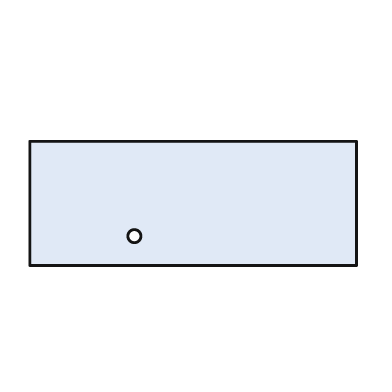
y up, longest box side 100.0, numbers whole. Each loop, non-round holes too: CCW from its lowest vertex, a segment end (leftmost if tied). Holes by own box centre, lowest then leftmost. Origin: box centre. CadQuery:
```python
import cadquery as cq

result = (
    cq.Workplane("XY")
    .moveTo(-50.0, -19.0)
    .lineTo(50.0, -19.0)
    .lineTo(50.0, 19.0)
    .lineTo(-50.0, 19.0)
    .close()
    .moveTo(-18.0, -10.0)
    .circle(2.0)
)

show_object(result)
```